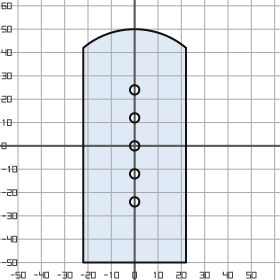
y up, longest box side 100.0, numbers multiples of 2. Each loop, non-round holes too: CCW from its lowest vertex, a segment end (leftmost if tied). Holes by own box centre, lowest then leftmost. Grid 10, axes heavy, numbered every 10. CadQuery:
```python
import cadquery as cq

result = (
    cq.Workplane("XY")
    .moveTo(-22.0, -50.0)
    .lineTo(22.0, -50.0)
    .lineTo(22.0, 42.0)
    .threePointArc((0.0, 50.0), (-22.0, 42.0))
    .close()
    .moveTo(0.0, -24.0)
    .circle(2.0)
    .moveTo(0.0, -12.0)
    .circle(2.0)
    .moveTo(0.0, 0.0)
    .circle(2.0)
    .moveTo(0.0, 12.0)
    .circle(2.0)
    .moveTo(0.0, 24.0)
    .circle(2.0)
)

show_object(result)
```